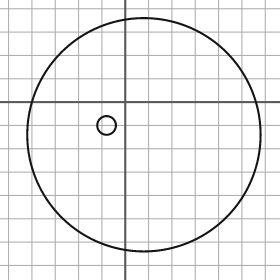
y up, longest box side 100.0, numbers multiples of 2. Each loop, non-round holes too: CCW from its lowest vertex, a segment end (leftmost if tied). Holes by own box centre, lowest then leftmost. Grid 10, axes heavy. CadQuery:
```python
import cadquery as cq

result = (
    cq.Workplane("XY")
    .moveTo(8.0, -14.0)
    .circle(50.0)
    .moveTo(-8.0, -10.0)
    .circle(4.0)
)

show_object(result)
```